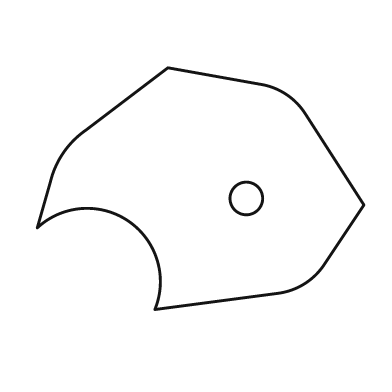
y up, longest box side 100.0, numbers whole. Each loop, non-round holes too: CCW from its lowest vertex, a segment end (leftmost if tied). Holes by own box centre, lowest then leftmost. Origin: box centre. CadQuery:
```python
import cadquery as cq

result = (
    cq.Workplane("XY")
    .moveTo(-14.0, -37.0)
    .lineTo(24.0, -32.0)
    .threePointArc((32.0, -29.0), (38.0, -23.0))
    .lineTo(50.0, -5.0)
    .lineTo(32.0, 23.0)
    .threePointArc((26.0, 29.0), (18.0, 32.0))
    .lineTo(-10.0, 37.0)
    .lineTo(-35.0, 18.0)
    .threePointArc((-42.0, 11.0), (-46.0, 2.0))
    .lineTo(-50.0, -12.0)
    .threePointArc((-22.0, -10.0), (-14.0, -37.0))
    .close()
    .moveTo(14.0, -3.0)
    .circle(5.0)
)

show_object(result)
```